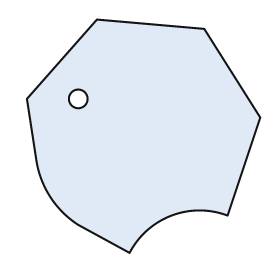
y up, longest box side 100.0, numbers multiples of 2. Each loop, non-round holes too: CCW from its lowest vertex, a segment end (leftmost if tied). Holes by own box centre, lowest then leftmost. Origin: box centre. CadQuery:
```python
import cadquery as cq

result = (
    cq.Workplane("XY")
    .moveTo(-6.0, -50.0)
    .threePointArc((12.0, -34.0), (36.0, -34.0))
    .lineTo(50.0, 8.0)
    .lineTo(26.0, 46.0)
    .lineTo(-20.0, 50.0)
    .lineTo(-50.0, 16.0)
    .lineTo(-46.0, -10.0)
    .threePointArc((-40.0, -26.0), (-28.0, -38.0))
    .close()
    .moveTo(-28.0, 16.0)
    .circle(4.0)
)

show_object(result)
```